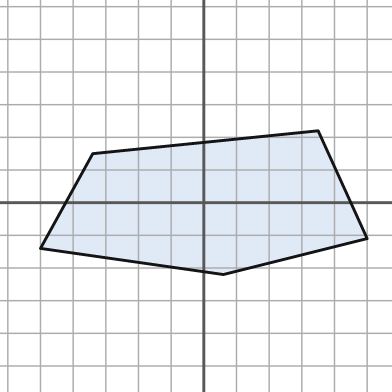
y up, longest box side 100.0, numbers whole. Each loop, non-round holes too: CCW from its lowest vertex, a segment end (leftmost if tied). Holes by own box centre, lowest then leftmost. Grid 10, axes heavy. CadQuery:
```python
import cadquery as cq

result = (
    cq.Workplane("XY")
    .moveTo(6.0, -22.0)
    .lineTo(50.0, -11.0)
    .lineTo(35.0, 22.0)
    .lineTo(-34.0, 15.0)
    .lineTo(-50.0, -14.0)
    .close()
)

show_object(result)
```